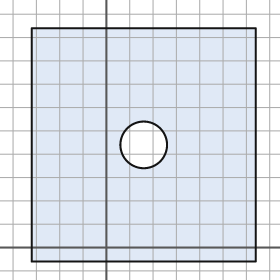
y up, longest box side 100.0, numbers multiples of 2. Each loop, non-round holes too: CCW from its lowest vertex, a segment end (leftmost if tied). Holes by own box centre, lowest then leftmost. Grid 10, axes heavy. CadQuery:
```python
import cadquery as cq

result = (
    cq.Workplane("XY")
    .moveTo(-32.0, -6.0)
    .lineTo(64.0, -6.0)
    .lineTo(64.0, 94.0)
    .lineTo(-32.0, 94.0)
    .close()
    .moveTo(16.0, 44.0)
    .circle(10.0)
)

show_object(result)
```